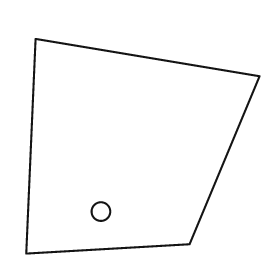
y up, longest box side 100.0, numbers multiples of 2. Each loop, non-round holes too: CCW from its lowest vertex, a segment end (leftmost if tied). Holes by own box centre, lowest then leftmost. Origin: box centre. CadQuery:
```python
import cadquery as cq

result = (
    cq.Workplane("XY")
    .moveTo(-50.0, -46.0)
    .lineTo(20.0, -42.0)
    .lineTo(50.0, 30.0)
    .lineTo(-46.0, 46.0)
    .close()
    .moveTo(-18.0, -28.0)
    .circle(4.0)
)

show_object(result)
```